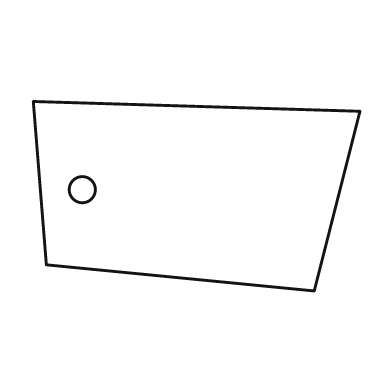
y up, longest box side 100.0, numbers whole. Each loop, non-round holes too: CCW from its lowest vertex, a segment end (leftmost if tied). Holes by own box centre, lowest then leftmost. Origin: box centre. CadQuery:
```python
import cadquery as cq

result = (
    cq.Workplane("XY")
    .moveTo(36.0, -29.0)
    .lineTo(50.0, 26.0)
    .lineTo(-50.0, 29.0)
    .lineTo(-46.0, -21.0)
    .close()
    .moveTo(-35.0, 2.0)
    .circle(4.0)
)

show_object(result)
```